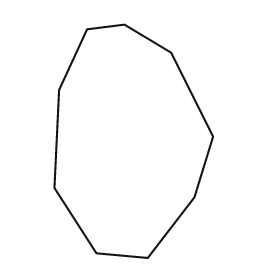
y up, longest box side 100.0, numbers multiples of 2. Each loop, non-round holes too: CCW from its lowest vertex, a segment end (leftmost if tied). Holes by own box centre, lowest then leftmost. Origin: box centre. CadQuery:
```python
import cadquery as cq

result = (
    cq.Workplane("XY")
    .moveTo(6.0, -50.0)
    .lineTo(26.0, -24.0)
    .lineTo(34.0, 2.0)
    .lineTo(16.0, 38.0)
    .lineTo(-4.0, 50.0)
    .lineTo(-20.0, 48.0)
    .lineTo(-32.0, 22.0)
    .lineTo(-34.0, -20.0)
    .lineTo(-16.0, -48.0)
    .close()
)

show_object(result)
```